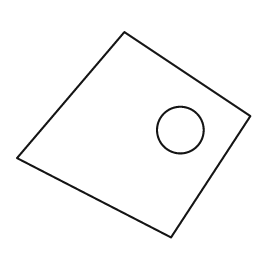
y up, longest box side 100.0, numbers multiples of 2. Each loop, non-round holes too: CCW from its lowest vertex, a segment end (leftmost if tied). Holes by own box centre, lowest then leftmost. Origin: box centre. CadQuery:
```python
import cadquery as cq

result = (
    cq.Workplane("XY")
    .moveTo(16.0, -44.0)
    .lineTo(50.0, 8.0)
    .lineTo(-4.0, 44.0)
    .lineTo(-50.0, -10.0)
    .close()
    .moveTo(20.0, 2.0)
    .circle(10.0)
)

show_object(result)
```